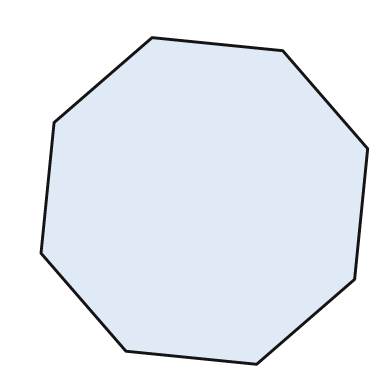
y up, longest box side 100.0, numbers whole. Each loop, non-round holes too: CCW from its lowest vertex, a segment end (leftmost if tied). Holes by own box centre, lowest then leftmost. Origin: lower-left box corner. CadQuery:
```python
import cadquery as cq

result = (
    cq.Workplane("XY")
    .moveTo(66.0, 0.0)
    .lineTo(96.0, 26.0)
    .lineTo(100.0, 66.0)
    .lineTo(74.0, 96.0)
    .lineTo(34.0, 100.0)
    .lineTo(4.0, 74.0)
    .lineTo(0.0, 34.0)
    .lineTo(26.0, 4.0)
    .close()
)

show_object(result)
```